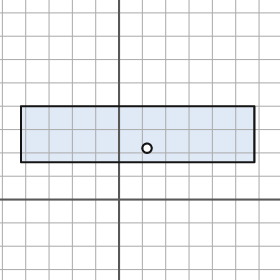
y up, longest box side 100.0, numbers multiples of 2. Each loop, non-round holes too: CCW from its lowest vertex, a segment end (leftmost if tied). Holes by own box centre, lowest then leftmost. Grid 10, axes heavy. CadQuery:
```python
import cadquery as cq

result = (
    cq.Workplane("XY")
    .moveTo(-42.0, 16.0)
    .lineTo(58.0, 16.0)
    .lineTo(58.0, 40.0)
    .lineTo(-42.0, 40.0)
    .close()
    .moveTo(12.0, 22.0)
    .circle(2.0)
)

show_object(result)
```